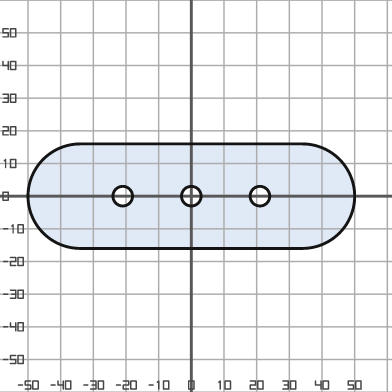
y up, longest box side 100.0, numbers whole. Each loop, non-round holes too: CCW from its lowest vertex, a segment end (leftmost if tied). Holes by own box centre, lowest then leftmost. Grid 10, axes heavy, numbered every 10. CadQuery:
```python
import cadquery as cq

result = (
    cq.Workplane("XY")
    .moveTo(-34.0, -16.0)
    .lineTo(34.0, -16.0)
    .threePointArc((50.0, 0.0), (34.0, 16.0))
    .lineTo(-34.0, 16.0)
    .threePointArc((-50.0, 0.0), (-34.0, -16.0))
    .close()
    .moveTo(-21.0, 0.0)
    .circle(3.0)
    .moveTo(0.0, 0.0)
    .circle(3.0)
    .moveTo(21.0, 0.0)
    .circle(3.0)
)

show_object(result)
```